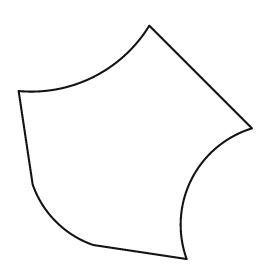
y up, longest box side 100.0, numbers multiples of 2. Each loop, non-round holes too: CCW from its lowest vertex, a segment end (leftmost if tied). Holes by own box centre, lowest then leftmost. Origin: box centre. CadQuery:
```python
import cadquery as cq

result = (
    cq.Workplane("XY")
    .moveTo(22.0, -50.0)
    .threePointArc((24.0, -16.0), (50.0, 6.0))
    .lineTo(6.0, 50.0)
    .threePointArc((-18.0, 28.0), (-50.0, 22.0))
    .lineTo(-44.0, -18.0)
    .threePointArc((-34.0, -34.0), (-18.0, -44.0))
    .close()
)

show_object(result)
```